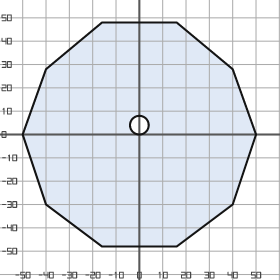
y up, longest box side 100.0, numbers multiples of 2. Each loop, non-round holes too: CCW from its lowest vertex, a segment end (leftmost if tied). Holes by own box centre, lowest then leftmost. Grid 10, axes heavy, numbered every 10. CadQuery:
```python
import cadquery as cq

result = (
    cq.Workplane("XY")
    .moveTo(-16.0, -48.0)
    .lineTo(16.0, -48.0)
    .lineTo(40.0, -30.0)
    .lineTo(50.0, 0.0)
    .lineTo(40.0, 28.0)
    .lineTo(16.0, 48.0)
    .lineTo(-16.0, 48.0)
    .lineTo(-40.0, 28.0)
    .lineTo(-50.0, 0.0)
    .lineTo(-40.0, -30.0)
    .close()
    .moveTo(0.0, 4.0)
    .circle(4.0)
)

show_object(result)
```